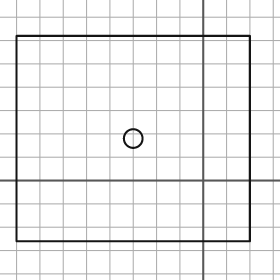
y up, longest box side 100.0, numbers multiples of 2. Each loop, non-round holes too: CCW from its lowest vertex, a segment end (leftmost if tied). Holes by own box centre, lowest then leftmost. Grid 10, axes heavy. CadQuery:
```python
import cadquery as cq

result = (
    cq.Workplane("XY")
    .moveTo(-80.0, -26.0)
    .lineTo(20.0, -26.0)
    .lineTo(20.0, 62.0)
    .lineTo(-80.0, 62.0)
    .close()
    .moveTo(-30.0, 18.0)
    .circle(4.0)
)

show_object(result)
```